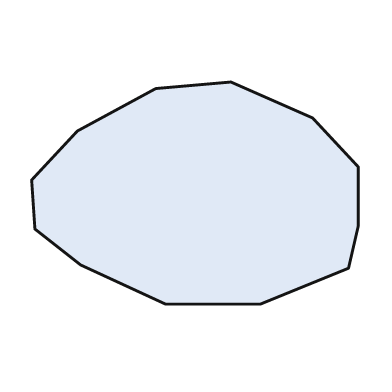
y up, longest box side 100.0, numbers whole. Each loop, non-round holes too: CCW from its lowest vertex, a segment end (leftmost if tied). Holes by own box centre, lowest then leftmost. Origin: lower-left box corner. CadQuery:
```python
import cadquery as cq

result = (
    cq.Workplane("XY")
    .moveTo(41.0, 0.0)
    .lineTo(70.0, 0.0)
    .lineTo(97.0, 11.0)
    .lineTo(100.0, 24.0)
    .lineTo(100.0, 42.0)
    .lineTo(86.0, 57.0)
    .lineTo(61.0, 68.0)
    .lineTo(38.0, 66.0)
    .lineTo(14.0, 53.0)
    .lineTo(0.0, 38.0)
    .lineTo(1.0, 23.0)
    .lineTo(15.0, 12.0)
    .close()
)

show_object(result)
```